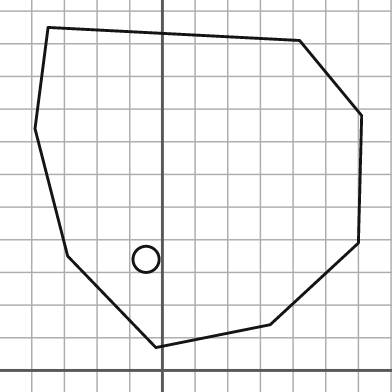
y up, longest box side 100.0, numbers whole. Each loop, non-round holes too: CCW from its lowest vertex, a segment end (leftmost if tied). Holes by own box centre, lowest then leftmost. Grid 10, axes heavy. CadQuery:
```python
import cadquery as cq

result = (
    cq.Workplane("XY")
    .moveTo(-2.0, 7.0)
    .lineTo(33.0, 14.0)
    .lineTo(60.0, 39.0)
    .lineTo(61.0, 78.0)
    .lineTo(42.0, 101.0)
    .lineTo(-35.0, 105.0)
    .lineTo(-39.0, 74.0)
    .lineTo(-29.0, 35.0)
    .close()
    .moveTo(-5.0, 34.0)
    .circle(4.0)
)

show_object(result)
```